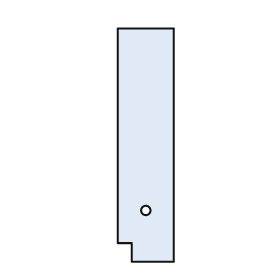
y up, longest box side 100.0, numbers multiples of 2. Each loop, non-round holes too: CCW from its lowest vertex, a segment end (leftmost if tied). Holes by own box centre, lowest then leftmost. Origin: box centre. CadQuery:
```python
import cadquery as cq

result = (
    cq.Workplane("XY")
    .moveTo(-6.0, -50.0)
    .lineTo(12.0, -50.0)
    .lineTo(12.0, 50.0)
    .lineTo(-12.0, 50.0)
    .lineTo(-12.0, -42.0)
    .lineTo(-6.0, -42.0)
    .close()
    .moveTo(0.0, -28.0)
    .circle(2.0)
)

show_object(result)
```